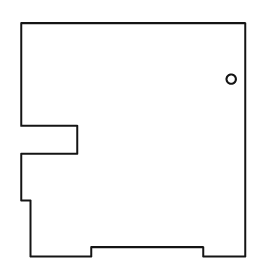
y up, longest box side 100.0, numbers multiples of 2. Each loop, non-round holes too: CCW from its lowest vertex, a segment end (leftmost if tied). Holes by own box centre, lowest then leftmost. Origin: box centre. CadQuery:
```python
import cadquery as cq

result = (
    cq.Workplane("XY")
    .moveTo(-44.0, -50.0)
    .lineTo(-18.0, -50.0)
    .lineTo(-18.0, -46.0)
    .lineTo(30.0, -46.0)
    .lineTo(30.0, -50.0)
    .lineTo(48.0, -50.0)
    .lineTo(48.0, 50.0)
    .lineTo(-48.0, 50.0)
    .lineTo(-48.0, 6.0)
    .lineTo(-24.0, 6.0)
    .lineTo(-24.0, -6.0)
    .lineTo(-48.0, -6.0)
    .lineTo(-48.0, -26.0)
    .lineTo(-44.0, -26.0)
    .close()
    .moveTo(42.0, 26.0)
    .circle(2.0)
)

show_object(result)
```